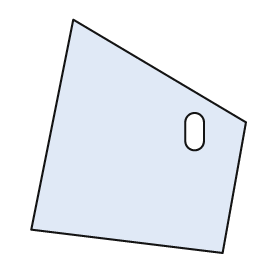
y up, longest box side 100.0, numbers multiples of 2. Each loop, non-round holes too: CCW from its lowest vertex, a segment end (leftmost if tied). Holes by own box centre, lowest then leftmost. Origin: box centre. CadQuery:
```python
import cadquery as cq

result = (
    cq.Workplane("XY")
    .moveTo(36.0, -50.0)
    .lineTo(46.0, 6.0)
    .lineTo(-28.0, 50.0)
    .lineTo(-46.0, -40.0)
    .close()
    .moveTo(20.0, -2.0)
    .threePointArc((24.0, -6.0), (28.0, -2.0))
    .lineTo(28.0, 6.0)
    .threePointArc((24.0, 10.0), (20.0, 6.0))
    .close()
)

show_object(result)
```